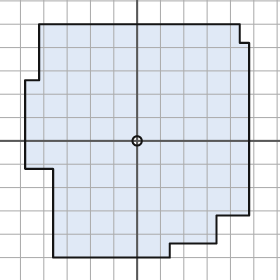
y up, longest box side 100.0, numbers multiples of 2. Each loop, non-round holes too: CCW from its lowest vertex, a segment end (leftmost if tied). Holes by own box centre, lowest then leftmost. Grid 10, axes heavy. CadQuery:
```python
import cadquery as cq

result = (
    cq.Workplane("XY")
    .moveTo(-36.0, -50.0)
    .lineTo(14.0, -50.0)
    .lineTo(14.0, -44.0)
    .lineTo(34.0, -44.0)
    .lineTo(34.0, -32.0)
    .lineTo(48.0, -32.0)
    .lineTo(48.0, 42.0)
    .lineTo(44.0, 42.0)
    .lineTo(44.0, 50.0)
    .lineTo(-42.0, 50.0)
    .lineTo(-42.0, 26.0)
    .lineTo(-48.0, 26.0)
    .lineTo(-48.0, -12.0)
    .lineTo(-36.0, -12.0)
    .close()
    .moveTo(0.0, 0.0)
    .circle(2.0)
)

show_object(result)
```